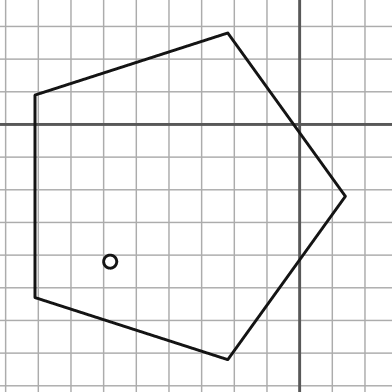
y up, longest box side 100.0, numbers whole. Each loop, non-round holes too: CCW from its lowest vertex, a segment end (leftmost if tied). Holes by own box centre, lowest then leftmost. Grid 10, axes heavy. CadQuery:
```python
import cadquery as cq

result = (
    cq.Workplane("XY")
    .moveTo(-22.0, -72.0)
    .lineTo(14.0, -22.0)
    .lineTo(-22.0, 28.0)
    .lineTo(-81.0, 9.0)
    .lineTo(-81.0, -53.0)
    .close()
    .moveTo(-58.0, -42.0)
    .circle(2.0)
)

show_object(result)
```